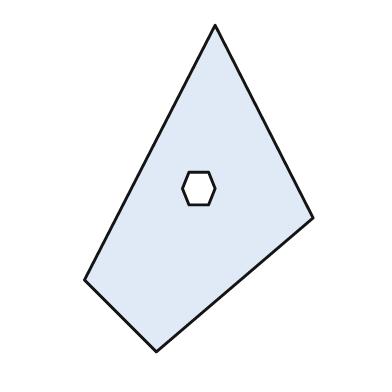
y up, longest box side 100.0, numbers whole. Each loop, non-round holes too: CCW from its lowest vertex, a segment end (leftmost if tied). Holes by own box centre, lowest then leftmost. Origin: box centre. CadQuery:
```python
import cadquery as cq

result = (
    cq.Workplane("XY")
    .moveTo(-13.0, -50.0)
    .lineTo(35.0, -9.0)
    .lineTo(5.0, 50.0)
    .lineTo(-35.0, -28.0)
    .close()
    .moveTo(-3.0, -5.0)
    .lineTo(3.0, -5.0)
    .lineTo(5.0, 0.0)
    .lineTo(3.0, 5.0)
    .lineTo(-3.0, 5.0)
    .lineTo(-5.0, 0.0)
    .close()
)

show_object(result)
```